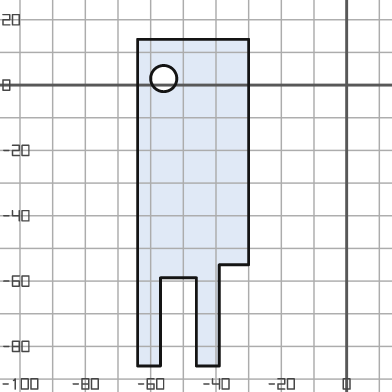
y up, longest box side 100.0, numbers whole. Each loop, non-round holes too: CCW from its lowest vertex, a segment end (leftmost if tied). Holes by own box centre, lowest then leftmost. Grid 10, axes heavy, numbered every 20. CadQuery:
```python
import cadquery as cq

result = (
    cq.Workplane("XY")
    .moveTo(-64.0, -86.0)
    .lineTo(-57.0, -86.0)
    .lineTo(-57.0, -59.0)
    .lineTo(-46.0, -59.0)
    .lineTo(-46.0, -86.0)
    .lineTo(-39.0, -86.0)
    .lineTo(-39.0, -55.0)
    .lineTo(-30.0, -55.0)
    .lineTo(-30.0, 14.0)
    .lineTo(-64.0, 14.0)
    .close()
    .moveTo(-56.0, 2.0)
    .circle(4.0)
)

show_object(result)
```